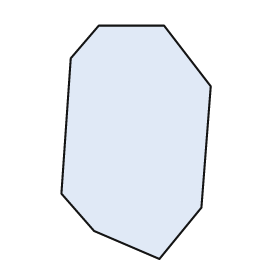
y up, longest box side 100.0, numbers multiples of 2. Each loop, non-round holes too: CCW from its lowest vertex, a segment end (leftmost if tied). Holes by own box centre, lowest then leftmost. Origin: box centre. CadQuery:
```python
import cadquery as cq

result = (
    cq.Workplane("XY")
    .moveTo(10.0, -50.0)
    .lineTo(28.0, -28.0)
    .lineTo(32.0, 24.0)
    .lineTo(12.0, 50.0)
    .lineTo(-16.0, 50.0)
    .lineTo(-28.0, 36.0)
    .lineTo(-32.0, -22.0)
    .lineTo(-18.0, -38.0)
    .close()
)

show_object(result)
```